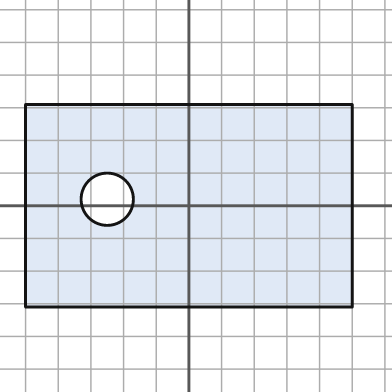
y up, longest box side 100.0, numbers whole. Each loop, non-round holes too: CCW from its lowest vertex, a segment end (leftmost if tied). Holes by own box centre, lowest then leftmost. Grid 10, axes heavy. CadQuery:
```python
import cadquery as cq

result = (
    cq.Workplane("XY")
    .moveTo(-50.0, -31.0)
    .lineTo(50.0, -31.0)
    .lineTo(50.0, 31.0)
    .lineTo(-50.0, 31.0)
    .close()
    .moveTo(-25.0, 2.0)
    .circle(8.0)
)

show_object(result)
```